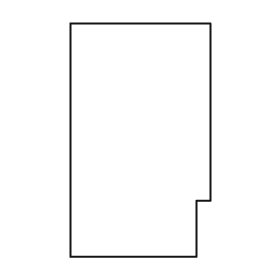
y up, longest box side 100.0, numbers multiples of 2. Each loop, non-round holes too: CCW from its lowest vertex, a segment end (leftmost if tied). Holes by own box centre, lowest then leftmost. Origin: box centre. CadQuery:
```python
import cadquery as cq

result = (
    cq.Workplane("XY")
    .moveTo(-30.0, -50.0)
    .lineTo(24.0, -50.0)
    .lineTo(24.0, -26.0)
    .lineTo(30.0, -26.0)
    .lineTo(30.0, 50.0)
    .lineTo(-30.0, 50.0)
    .close()
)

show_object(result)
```